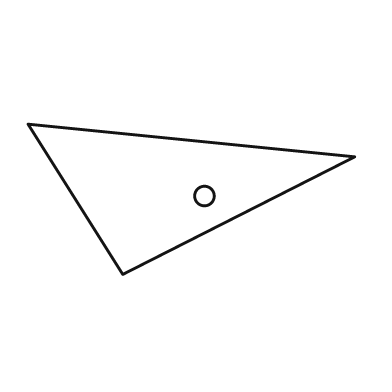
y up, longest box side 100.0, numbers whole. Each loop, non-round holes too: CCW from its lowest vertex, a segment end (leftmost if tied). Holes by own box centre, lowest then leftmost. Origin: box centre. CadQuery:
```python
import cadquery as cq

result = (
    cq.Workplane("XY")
    .moveTo(-21.0, -23.0)
    .lineTo(50.0, 13.0)
    .lineTo(-50.0, 23.0)
    .close()
    .moveTo(4.0, 1.0)
    .circle(3.0)
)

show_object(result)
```